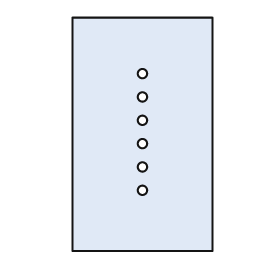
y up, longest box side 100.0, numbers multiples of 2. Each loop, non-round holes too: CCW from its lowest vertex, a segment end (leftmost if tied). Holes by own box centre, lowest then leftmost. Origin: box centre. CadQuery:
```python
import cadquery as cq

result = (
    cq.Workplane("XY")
    .moveTo(-30.0, -50.0)
    .lineTo(30.0, -50.0)
    .lineTo(30.0, 50.0)
    .lineTo(-30.0, 50.0)
    .close()
    .moveTo(0.0, -24.0)
    .circle(2.0)
    .moveTo(0.0, -14.0)
    .circle(2.0)
    .moveTo(0.0, -4.0)
    .circle(2.0)
    .moveTo(0.0, 6.0)
    .circle(2.0)
    .moveTo(0.0, 16.0)
    .circle(2.0)
    .moveTo(0.0, 26.0)
    .circle(2.0)
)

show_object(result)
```